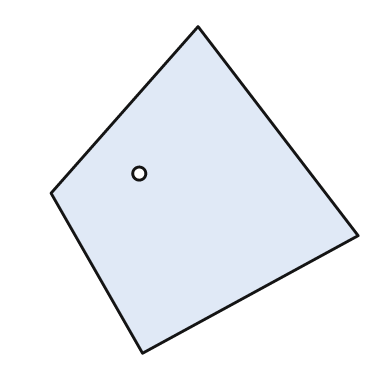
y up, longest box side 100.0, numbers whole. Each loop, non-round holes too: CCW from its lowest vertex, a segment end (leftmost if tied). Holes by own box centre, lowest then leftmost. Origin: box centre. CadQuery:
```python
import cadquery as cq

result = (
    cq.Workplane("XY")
    .moveTo(-19.0, -50.0)
    .lineTo(47.0, -14.0)
    .lineTo(-2.0, 50.0)
    .lineTo(-47.0, -1.0)
    .close()
    .moveTo(-20.0, 5.0)
    .circle(2.0)
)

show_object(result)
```